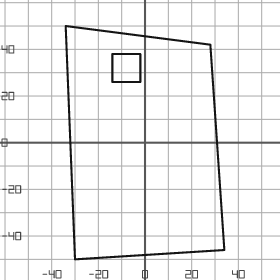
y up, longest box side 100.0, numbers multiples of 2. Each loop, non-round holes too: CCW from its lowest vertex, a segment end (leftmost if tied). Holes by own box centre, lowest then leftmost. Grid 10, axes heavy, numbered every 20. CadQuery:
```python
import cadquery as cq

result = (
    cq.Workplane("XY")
    .moveTo(-30.0, -50.0)
    .lineTo(34.0, -46.0)
    .lineTo(28.0, 42.0)
    .lineTo(-34.0, 50.0)
    .close()
    .moveTo(-14.0, 26.0)
    .lineTo(-2.0, 26.0)
    .lineTo(-2.0, 38.0)
    .lineTo(-14.0, 38.0)
    .close()
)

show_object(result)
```